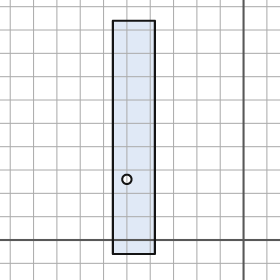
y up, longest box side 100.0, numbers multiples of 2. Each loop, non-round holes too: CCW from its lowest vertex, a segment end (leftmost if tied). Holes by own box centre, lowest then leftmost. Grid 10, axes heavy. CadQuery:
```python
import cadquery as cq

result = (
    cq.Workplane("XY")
    .moveTo(-56.0, -6.0)
    .lineTo(-38.0, -6.0)
    .lineTo(-38.0, 94.0)
    .lineTo(-56.0, 94.0)
    .close()
    .moveTo(-50.0, 26.0)
    .circle(2.0)
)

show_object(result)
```